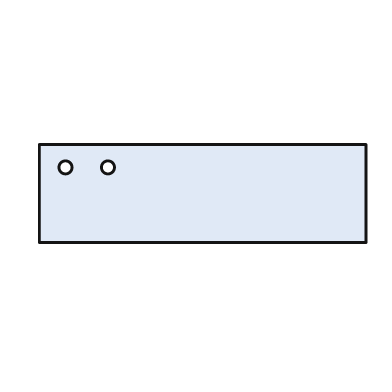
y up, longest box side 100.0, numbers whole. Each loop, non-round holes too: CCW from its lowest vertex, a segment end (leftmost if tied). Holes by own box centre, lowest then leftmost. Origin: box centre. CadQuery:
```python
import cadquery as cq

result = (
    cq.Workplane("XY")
    .moveTo(-50.0, -15.0)
    .lineTo(50.0, -15.0)
    .lineTo(50.0, 15.0)
    .lineTo(-50.0, 15.0)
    .close()
    .moveTo(-42.0, 8.0)
    .circle(2.0)
    .moveTo(-29.0, 8.0)
    .circle(2.0)
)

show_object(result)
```